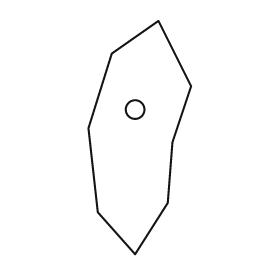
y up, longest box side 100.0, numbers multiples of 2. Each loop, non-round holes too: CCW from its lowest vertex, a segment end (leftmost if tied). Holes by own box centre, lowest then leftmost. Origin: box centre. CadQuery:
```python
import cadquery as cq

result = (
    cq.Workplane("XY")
    .moveTo(-2.0, -50.0)
    .lineTo(12.0, -28.0)
    .lineTo(14.0, -2.0)
    .lineTo(22.0, 22.0)
    .lineTo(8.0, 50.0)
    .lineTo(-12.0, 36.0)
    .lineTo(-22.0, 4.0)
    .lineTo(-18.0, -32.0)
    .close()
    .moveTo(-2.0, 12.0)
    .circle(4.0)
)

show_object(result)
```